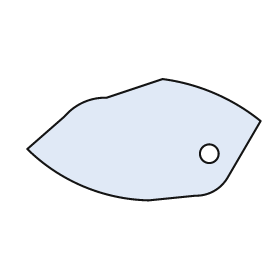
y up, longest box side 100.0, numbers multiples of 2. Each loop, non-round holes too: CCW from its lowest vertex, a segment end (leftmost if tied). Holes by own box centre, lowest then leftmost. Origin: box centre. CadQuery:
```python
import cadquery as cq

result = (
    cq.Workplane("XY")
    .moveTo(2.0, -26.0)
    .lineTo(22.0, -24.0)
    .threePointArc((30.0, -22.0), (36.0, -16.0))
    .lineTo(50.0, 8.0)
    .threePointArc((30.0, 20.0), (8.0, 26.0))
    .lineTo(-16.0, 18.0)
    .threePointArc((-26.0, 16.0), (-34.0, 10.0))
    .lineTo(-50.0, -4.0)
    .threePointArc((-26.0, -20.0), (2.0, -26.0))
    .close()
    .moveTo(28.0, -6.0)
    .circle(4.0)
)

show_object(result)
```